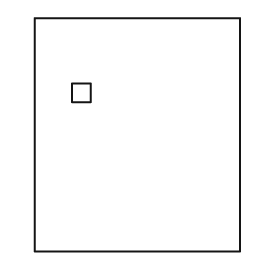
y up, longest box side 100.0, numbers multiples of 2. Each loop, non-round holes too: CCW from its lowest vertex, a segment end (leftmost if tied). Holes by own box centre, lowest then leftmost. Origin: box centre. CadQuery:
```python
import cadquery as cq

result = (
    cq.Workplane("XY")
    .moveTo(-44.0, -50.0)
    .lineTo(44.0, -50.0)
    .lineTo(44.0, 50.0)
    .lineTo(-44.0, 50.0)
    .close()
    .moveTo(-28.0, 14.0)
    .lineTo(-20.0, 14.0)
    .lineTo(-20.0, 22.0)
    .lineTo(-28.0, 22.0)
    .close()
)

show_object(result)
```